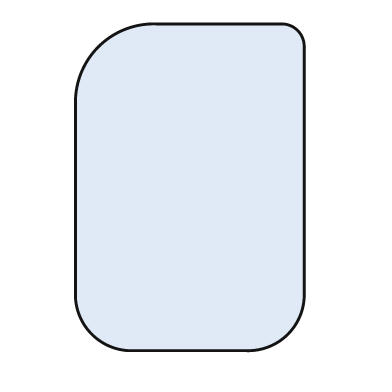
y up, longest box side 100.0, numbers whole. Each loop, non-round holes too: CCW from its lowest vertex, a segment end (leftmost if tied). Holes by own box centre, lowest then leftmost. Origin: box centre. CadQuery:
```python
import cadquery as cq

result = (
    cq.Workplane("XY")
    .moveTo(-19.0, -50.0)
    .lineTo(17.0, -50.0)
    .threePointArc((30.0, -45.0), (35.0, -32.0))
    .lineTo(35.0, 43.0)
    .threePointArc((33.0, 48.0), (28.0, 50.0))
    .lineTo(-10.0, 50.0)
    .threePointArc((-28.0, 43.0), (-35.0, 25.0))
    .lineTo(-35.0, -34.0)
    .threePointArc((-30.0, -45.0), (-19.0, -50.0))
    .close()
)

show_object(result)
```